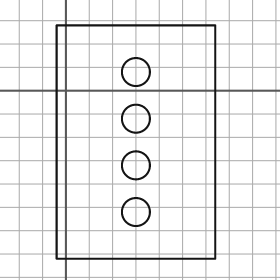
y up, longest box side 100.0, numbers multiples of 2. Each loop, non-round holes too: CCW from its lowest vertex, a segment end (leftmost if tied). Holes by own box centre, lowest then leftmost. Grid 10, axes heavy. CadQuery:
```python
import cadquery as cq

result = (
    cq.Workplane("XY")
    .moveTo(-4.0, -72.0)
    .lineTo(64.0, -72.0)
    .lineTo(64.0, 28.0)
    .lineTo(-4.0, 28.0)
    .close()
    .moveTo(30.0, -52.0)
    .circle(6.0)
    .moveTo(30.0, -32.0)
    .circle(6.0)
    .moveTo(30.0, -12.0)
    .circle(6.0)
    .moveTo(30.0, 8.0)
    .circle(6.0)
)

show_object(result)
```